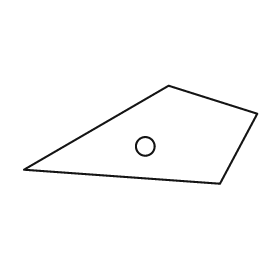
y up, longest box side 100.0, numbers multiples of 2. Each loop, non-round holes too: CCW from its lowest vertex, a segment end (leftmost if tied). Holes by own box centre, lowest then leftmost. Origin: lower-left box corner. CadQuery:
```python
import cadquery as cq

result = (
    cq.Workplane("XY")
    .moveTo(84.0, 0.0)
    .lineTo(100.0, 30.0)
    .lineTo(62.0, 42.0)
    .lineTo(0.0, 6.0)
    .close()
    .moveTo(52.0, 16.0)
    .circle(4.0)
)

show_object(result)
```